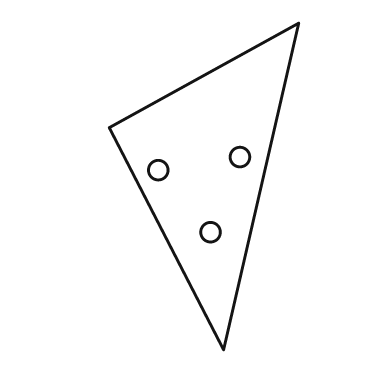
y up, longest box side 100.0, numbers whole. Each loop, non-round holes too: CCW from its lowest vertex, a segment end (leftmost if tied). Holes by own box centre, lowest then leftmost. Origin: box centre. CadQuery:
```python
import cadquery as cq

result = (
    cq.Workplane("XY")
    .moveTo(6.0, -50.0)
    .lineTo(29.0, 50.0)
    .lineTo(-29.0, 18.0)
    .close()
    .moveTo(2.0, -14.0)
    .circle(3.0)
    .moveTo(-14.0, 5.0)
    .circle(3.0)
    .moveTo(11.0, 9.0)
    .circle(3.0)
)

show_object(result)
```